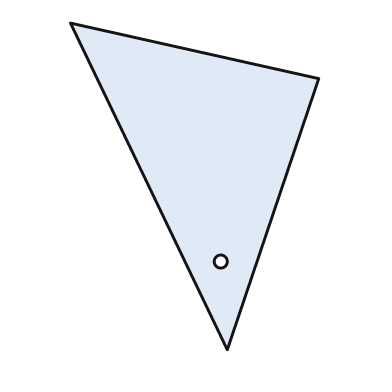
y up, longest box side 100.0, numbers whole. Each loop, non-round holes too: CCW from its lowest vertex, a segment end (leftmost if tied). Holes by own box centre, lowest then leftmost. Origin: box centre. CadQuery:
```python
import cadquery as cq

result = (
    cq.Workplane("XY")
    .moveTo(10.0, -50.0)
    .lineTo(38.0, 33.0)
    .lineTo(-38.0, 50.0)
    .close()
    .moveTo(8.0, -23.0)
    .circle(2.0)
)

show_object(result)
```